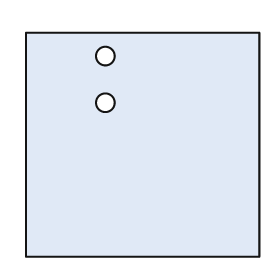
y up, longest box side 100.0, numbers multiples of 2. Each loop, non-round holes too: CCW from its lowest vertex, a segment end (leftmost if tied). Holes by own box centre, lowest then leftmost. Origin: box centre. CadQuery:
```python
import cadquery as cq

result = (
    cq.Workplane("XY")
    .moveTo(-50.0, -48.0)
    .lineTo(50.0, -48.0)
    .lineTo(50.0, 48.0)
    .lineTo(-50.0, 48.0)
    .close()
    .moveTo(-16.0, 18.0)
    .circle(4.0)
    .moveTo(-16.0, 38.0)
    .circle(4.0)
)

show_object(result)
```